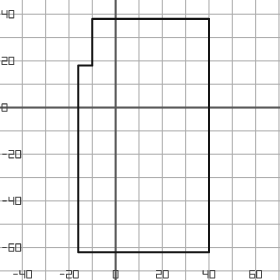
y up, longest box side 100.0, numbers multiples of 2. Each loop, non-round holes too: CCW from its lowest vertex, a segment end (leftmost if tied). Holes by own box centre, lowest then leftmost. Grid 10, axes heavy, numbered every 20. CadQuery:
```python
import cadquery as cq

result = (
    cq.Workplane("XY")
    .moveTo(-16.0, -62.0)
    .lineTo(40.0, -62.0)
    .lineTo(40.0, 38.0)
    .lineTo(-10.0, 38.0)
    .lineTo(-10.0, 18.0)
    .lineTo(-16.0, 18.0)
    .close()
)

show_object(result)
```